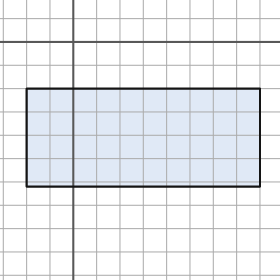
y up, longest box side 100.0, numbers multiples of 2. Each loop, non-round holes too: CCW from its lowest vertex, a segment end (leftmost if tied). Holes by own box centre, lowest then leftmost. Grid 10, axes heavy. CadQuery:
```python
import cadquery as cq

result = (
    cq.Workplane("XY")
    .moveTo(-20.0, -62.0)
    .lineTo(80.0, -62.0)
    .lineTo(80.0, -20.0)
    .lineTo(-20.0, -20.0)
    .close()
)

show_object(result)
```